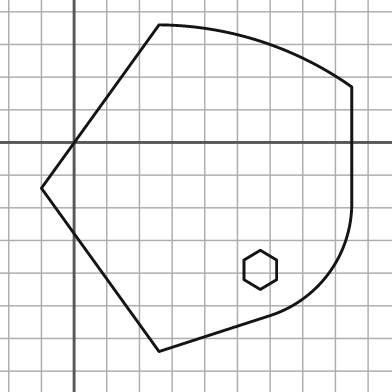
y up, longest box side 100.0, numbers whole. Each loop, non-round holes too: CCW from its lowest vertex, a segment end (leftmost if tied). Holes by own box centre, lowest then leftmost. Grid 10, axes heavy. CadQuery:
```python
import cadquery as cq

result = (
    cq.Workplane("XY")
    .moveTo(26.0, -64.0)
    .lineTo(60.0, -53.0)
    .threePointArc((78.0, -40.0), (85.0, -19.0))
    .lineTo(85.0, 17.0)
    .threePointArc((57.0, 31.0), (26.0, 36.0))
    .lineTo(-10.0, -14.0)
    .close()
    .moveTo(57.0, -45.0)
    .lineTo(62.0, -42.0)
    .lineTo(62.0, -36.0)
    .lineTo(57.0, -33.0)
    .lineTo(52.0, -36.0)
    .lineTo(52.0, -42.0)
    .close()
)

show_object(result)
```